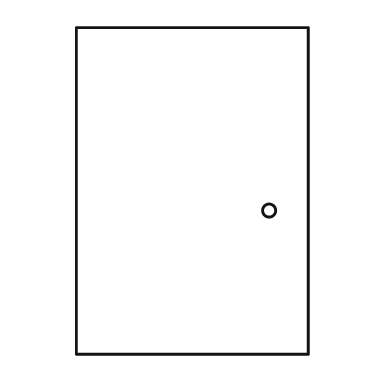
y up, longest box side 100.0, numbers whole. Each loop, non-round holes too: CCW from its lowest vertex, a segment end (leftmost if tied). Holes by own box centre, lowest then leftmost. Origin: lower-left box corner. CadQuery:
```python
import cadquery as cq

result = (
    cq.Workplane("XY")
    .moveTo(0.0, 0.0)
    .lineTo(71.0, 0.0)
    .lineTo(71.0, 100.0)
    .lineTo(0.0, 100.0)
    .close()
    .moveTo(59.0, 44.0)
    .circle(2.0)
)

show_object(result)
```